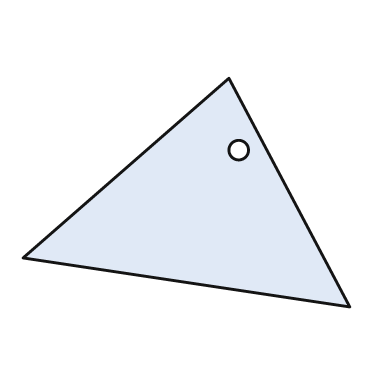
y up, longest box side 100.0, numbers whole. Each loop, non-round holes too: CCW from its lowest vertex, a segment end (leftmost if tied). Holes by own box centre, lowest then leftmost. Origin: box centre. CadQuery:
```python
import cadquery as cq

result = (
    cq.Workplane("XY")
    .moveTo(50.0, -35.0)
    .lineTo(13.0, 35.0)
    .lineTo(-50.0, -20.0)
    .close()
    .moveTo(16.0, 13.0)
    .circle(3.0)
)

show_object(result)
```